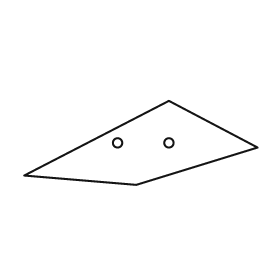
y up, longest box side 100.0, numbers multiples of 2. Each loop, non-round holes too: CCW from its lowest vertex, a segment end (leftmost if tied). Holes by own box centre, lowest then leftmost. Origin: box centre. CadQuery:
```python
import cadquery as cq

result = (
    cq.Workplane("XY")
    .moveTo(-2.0, -18.0)
    .lineTo(50.0, -2.0)
    .lineTo(12.0, 18.0)
    .lineTo(-50.0, -14.0)
    .close()
    .moveTo(-10.0, 0.0)
    .circle(2.0)
    .moveTo(12.0, 0.0)
    .circle(2.0)
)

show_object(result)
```